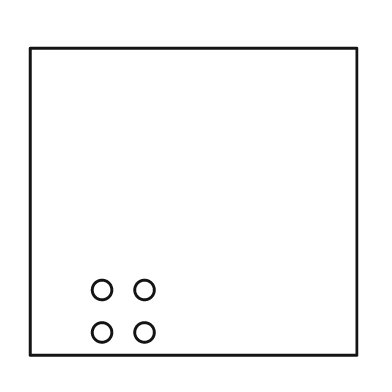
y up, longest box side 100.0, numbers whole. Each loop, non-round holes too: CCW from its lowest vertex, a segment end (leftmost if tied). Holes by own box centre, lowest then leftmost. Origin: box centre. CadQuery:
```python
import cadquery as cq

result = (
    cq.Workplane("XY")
    .moveTo(-50.0, -47.0)
    .lineTo(50.0, -47.0)
    .lineTo(50.0, 47.0)
    .lineTo(-50.0, 47.0)
    .close()
    .moveTo(-28.0, -40.0)
    .circle(3.0)
    .moveTo(-15.0, -40.0)
    .circle(3.0)
    .moveTo(-28.0, -27.0)
    .circle(3.0)
    .moveTo(-15.0, -27.0)
    .circle(3.0)
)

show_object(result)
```